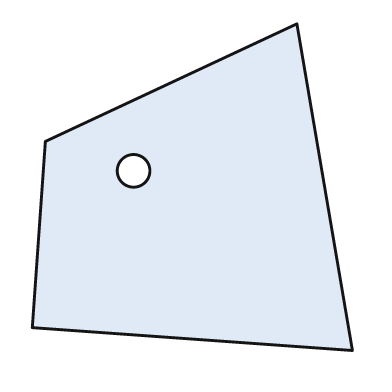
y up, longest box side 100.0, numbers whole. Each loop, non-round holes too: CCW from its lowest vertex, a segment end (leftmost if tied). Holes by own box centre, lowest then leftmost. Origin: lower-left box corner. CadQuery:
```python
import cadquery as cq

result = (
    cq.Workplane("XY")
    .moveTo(98.0, 0.0)
    .lineTo(81.0, 100.0)
    .lineTo(4.0, 64.0)
    .lineTo(0.0, 7.0)
    .close()
    .moveTo(31.0, 55.0)
    .circle(5.0)
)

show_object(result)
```